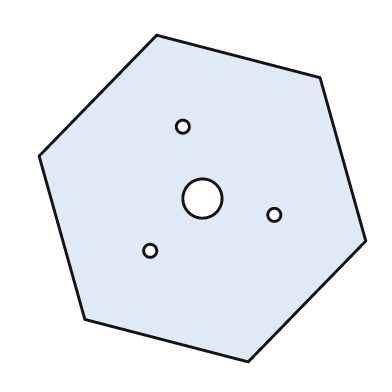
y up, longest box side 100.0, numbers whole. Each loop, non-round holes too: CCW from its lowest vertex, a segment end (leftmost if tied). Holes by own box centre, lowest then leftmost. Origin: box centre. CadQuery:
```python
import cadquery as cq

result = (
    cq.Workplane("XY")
    .moveTo(14.0, -50.0)
    .lineTo(50.0, -13.0)
    .lineTo(36.0, 37.0)
    .lineTo(-14.0, 50.0)
    .lineTo(-50.0, 13.0)
    .lineTo(-36.0, -37.0)
    .close()
    .moveTo(-16.0, -16.0)
    .circle(2.0)
    .moveTo(22.0, -5.0)
    .circle(2.0)
    .moveTo(0.0, 0.0)
    .circle(6.0)
    .moveTo(-6.0, 22.0)
    .circle(2.0)
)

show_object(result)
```